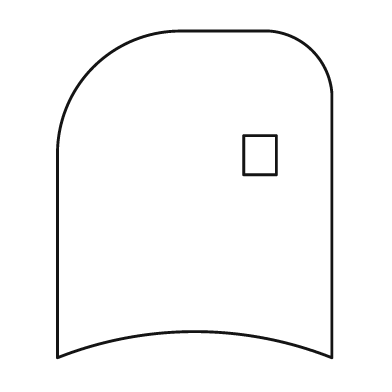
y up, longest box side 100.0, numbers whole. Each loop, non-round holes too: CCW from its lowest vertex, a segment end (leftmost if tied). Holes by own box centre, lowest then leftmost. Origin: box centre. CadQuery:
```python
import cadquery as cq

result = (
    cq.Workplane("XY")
    .moveTo(-42.0, -50.0)
    .threePointArc((0.0, -42.0), (42.0, -50.0))
    .lineTo(42.0, 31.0)
    .threePointArc((36.0, 44.0), (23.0, 50.0))
    .lineTo(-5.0, 50.0)
    .threePointArc((-31.0, 39.0), (-42.0, 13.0))
    .close()
    .moveTo(15.0, 6.0)
    .lineTo(25.0, 6.0)
    .lineTo(25.0, 18.0)
    .lineTo(15.0, 18.0)
    .close()
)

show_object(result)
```